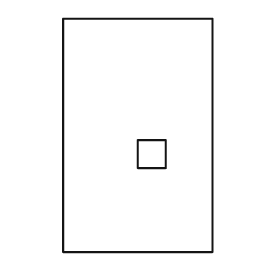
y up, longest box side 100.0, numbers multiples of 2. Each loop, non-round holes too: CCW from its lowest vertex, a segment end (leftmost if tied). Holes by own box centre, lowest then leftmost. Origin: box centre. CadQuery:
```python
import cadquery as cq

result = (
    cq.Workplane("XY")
    .moveTo(-32.0, -50.0)
    .lineTo(32.0, -50.0)
    .lineTo(32.0, 50.0)
    .lineTo(-32.0, 50.0)
    .close()
    .moveTo(0.0, -14.0)
    .lineTo(12.0, -14.0)
    .lineTo(12.0, -2.0)
    .lineTo(0.0, -2.0)
    .close()
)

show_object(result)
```